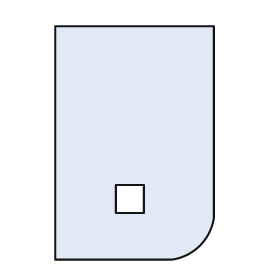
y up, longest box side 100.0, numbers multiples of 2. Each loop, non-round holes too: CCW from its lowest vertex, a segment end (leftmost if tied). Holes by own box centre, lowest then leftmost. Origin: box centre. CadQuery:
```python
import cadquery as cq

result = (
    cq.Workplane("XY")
    .moveTo(-34.0, -50.0)
    .lineTo(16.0, -50.0)
    .threePointArc((28.0, -44.0), (34.0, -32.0))
    .lineTo(34.0, 50.0)
    .lineTo(-34.0, 50.0)
    .close()
    .moveTo(-8.0, -30.0)
    .lineTo(4.0, -30.0)
    .lineTo(4.0, -18.0)
    .lineTo(-8.0, -18.0)
    .close()
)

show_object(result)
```